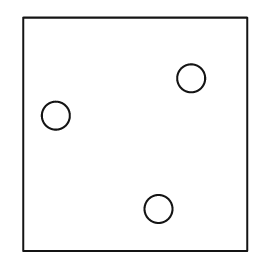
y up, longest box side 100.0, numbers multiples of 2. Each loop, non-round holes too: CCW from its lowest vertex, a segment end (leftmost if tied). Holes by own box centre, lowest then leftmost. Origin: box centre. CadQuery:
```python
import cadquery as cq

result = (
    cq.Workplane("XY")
    .moveTo(-48.0, -50.0)
    .lineTo(48.0, -50.0)
    .lineTo(48.0, 50.0)
    .lineTo(-48.0, 50.0)
    .close()
    .moveTo(10.0, -32.0)
    .circle(6.0)
    .moveTo(-34.0, 8.0)
    .circle(6.0)
    .moveTo(24.0, 24.0)
    .circle(6.0)
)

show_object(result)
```